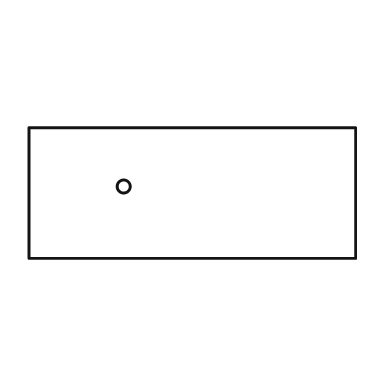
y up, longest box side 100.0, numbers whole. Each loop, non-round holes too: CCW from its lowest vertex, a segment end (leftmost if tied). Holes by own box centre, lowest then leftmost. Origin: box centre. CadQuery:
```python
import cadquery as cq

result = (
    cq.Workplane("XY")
    .moveTo(-50.0, -20.0)
    .lineTo(50.0, -20.0)
    .lineTo(50.0, 20.0)
    .lineTo(-50.0, 20.0)
    .close()
    .moveTo(-21.0, 2.0)
    .circle(2.0)
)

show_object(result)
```